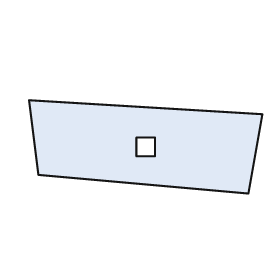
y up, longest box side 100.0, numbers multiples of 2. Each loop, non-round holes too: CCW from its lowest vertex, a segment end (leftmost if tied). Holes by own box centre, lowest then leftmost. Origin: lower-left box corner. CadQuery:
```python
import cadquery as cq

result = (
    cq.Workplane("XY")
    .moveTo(94.0, 0.0)
    .lineTo(100.0, 34.0)
    .lineTo(0.0, 40.0)
    .lineTo(4.0, 8.0)
    .close()
    .moveTo(46.0, 16.0)
    .lineTo(54.0, 16.0)
    .lineTo(54.0, 24.0)
    .lineTo(46.0, 24.0)
    .close()
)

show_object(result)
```